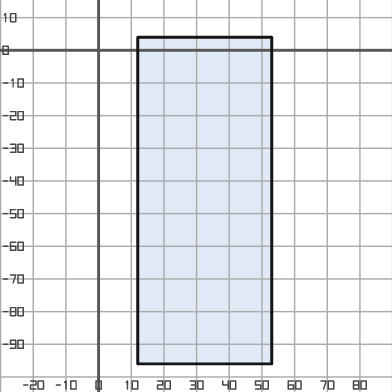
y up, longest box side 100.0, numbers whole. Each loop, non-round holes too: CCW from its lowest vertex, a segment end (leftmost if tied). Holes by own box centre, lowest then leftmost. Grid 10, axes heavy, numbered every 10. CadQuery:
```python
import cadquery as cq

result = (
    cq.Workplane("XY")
    .moveTo(12.0, -96.0)
    .lineTo(53.0, -96.0)
    .lineTo(53.0, 4.0)
    .lineTo(12.0, 4.0)
    .close()
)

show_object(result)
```